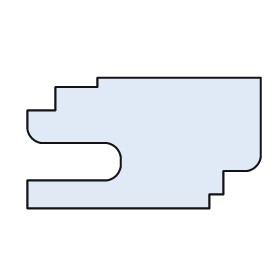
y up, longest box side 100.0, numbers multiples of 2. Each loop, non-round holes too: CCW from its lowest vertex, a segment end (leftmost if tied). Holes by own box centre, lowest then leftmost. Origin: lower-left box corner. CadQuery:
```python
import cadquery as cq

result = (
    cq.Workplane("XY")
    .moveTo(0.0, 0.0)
    .lineTo(78.0, 0.0)
    .lineTo(78.0, 6.0)
    .lineTo(84.0, 6.0)
    .lineTo(84.0, 16.0)
    .lineTo(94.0, 16.0)
    .threePointArc((98.0, 18.0), (100.0, 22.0))
    .lineTo(100.0, 56.0)
    .lineTo(30.0, 56.0)
    .lineTo(30.0, 52.0)
    .lineTo(12.0, 52.0)
    .lineTo(12.0, 42.0)
    .lineTo(0.0, 42.0)
    .lineTo(0.0, 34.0)
    .threePointArc((2.0, 30.0), (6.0, 28.0))
    .lineTo(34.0, 28.0)
    .threePointArc((38.0, 26.0), (40.0, 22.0))
    .lineTo(40.0, 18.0)
    .threePointArc((38.0, 14.0), (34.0, 12.0))
    .lineTo(0.0, 12.0)
    .close()
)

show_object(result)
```